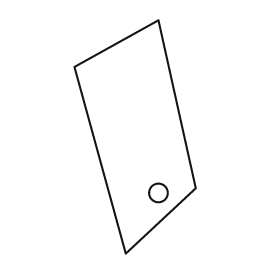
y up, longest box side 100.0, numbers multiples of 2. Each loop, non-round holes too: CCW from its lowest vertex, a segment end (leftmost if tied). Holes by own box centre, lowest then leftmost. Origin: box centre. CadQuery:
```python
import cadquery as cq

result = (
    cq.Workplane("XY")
    .moveTo(-4.0, -50.0)
    .lineTo(26.0, -22.0)
    .lineTo(10.0, 50.0)
    .lineTo(-26.0, 30.0)
    .close()
    .moveTo(10.0, -24.0)
    .circle(4.0)
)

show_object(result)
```